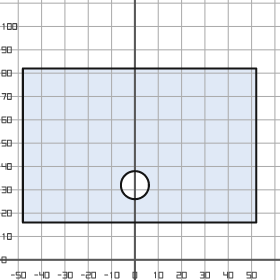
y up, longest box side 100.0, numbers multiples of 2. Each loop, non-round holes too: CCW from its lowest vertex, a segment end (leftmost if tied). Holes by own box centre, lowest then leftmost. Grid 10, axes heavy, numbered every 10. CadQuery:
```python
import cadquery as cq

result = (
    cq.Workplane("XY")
    .moveTo(-48.0, 16.0)
    .lineTo(52.0, 16.0)
    .lineTo(52.0, 82.0)
    .lineTo(-48.0, 82.0)
    .close()
    .moveTo(0.0, 32.0)
    .circle(6.0)
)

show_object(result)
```